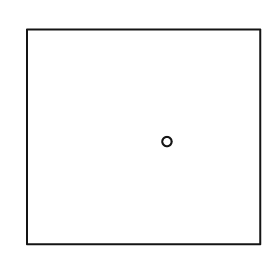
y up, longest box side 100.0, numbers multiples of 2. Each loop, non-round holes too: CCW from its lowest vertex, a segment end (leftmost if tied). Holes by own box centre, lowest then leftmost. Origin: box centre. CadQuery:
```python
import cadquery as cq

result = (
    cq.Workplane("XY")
    .moveTo(-50.0, -46.0)
    .lineTo(50.0, -46.0)
    .lineTo(50.0, 46.0)
    .lineTo(-50.0, 46.0)
    .close()
    .moveTo(10.0, -2.0)
    .circle(2.0)
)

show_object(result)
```